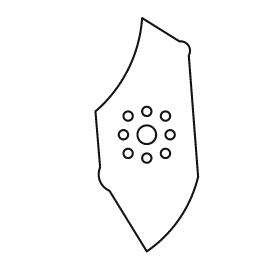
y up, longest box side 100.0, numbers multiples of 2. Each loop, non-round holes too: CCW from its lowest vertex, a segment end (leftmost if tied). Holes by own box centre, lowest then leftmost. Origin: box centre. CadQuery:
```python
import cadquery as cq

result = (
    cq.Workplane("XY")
    .moveTo(0.0, -50.0)
    .threePointArc((14.0, -36.0), (22.0, -18.0))
    .lineTo(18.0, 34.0)
    .threePointArc((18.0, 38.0), (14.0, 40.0))
    .lineTo(-2.0, 50.0)
    .threePointArc((-8.0, 28.0), (-22.0, 10.0))
    .lineTo(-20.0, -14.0)
    .threePointArc((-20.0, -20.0), (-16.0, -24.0))
    .close()
    .moveTo(0.0, -10.0)
    .circle(2.0)
    .moveTo(-8.0, -8.0)
    .circle(2.0)
    .moveTo(8.0, -8.0)
    .circle(2.0)
    .moveTo(-10.0, 0.0)
    .circle(2.0)
    .moveTo(0.0, 0.0)
    .circle(4.0)
    .moveTo(10.0, 0.0)
    .circle(2.0)
    .moveTo(-8.0, 8.0)
    .circle(2.0)
    .moveTo(8.0, 8.0)
    .circle(2.0)
    .moveTo(0.0, 10.0)
    .circle(2.0)
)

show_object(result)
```